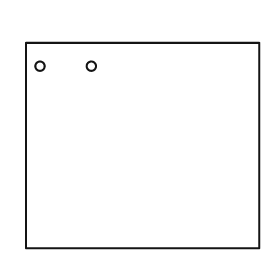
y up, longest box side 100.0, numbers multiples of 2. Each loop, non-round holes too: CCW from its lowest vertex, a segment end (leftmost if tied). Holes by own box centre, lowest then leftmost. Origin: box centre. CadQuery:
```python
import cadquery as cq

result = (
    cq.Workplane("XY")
    .moveTo(-50.0, -44.0)
    .lineTo(50.0, -44.0)
    .lineTo(50.0, 44.0)
    .lineTo(-50.0, 44.0)
    .close()
    .moveTo(-44.0, 34.0)
    .circle(2.0)
    .moveTo(-22.0, 34.0)
    .circle(2.0)
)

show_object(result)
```